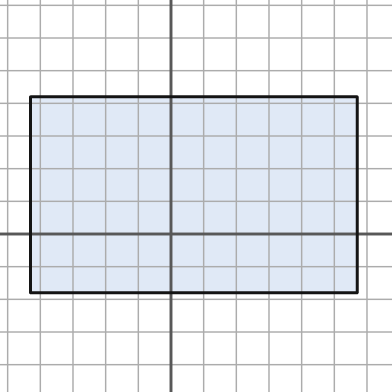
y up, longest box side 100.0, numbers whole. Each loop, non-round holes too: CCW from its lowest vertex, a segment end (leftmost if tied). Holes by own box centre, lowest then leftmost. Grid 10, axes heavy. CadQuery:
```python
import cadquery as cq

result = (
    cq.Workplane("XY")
    .moveTo(-43.0, -18.0)
    .lineTo(57.0, -18.0)
    .lineTo(57.0, 42.0)
    .lineTo(-43.0, 42.0)
    .close()
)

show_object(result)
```